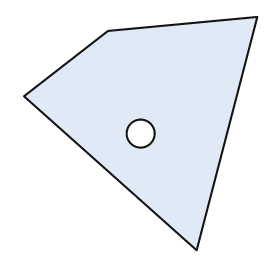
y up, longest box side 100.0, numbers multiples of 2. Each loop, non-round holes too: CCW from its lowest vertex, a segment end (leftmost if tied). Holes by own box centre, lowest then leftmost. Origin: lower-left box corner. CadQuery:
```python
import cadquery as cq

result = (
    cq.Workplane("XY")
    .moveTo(74.0, 0.0)
    .lineTo(100.0, 100.0)
    .lineTo(36.0, 94.0)
    .lineTo(0.0, 66.0)
    .close()
    .moveTo(50.0, 50.0)
    .circle(6.0)
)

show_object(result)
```